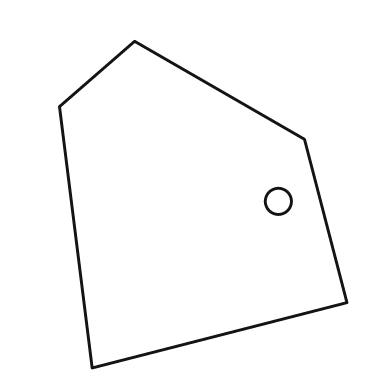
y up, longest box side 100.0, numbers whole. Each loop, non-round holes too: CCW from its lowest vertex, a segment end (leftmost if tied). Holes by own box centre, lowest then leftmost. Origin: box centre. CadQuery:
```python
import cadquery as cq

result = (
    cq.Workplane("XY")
    .moveTo(-34.0, -50.0)
    .lineTo(44.0, -30.0)
    .lineTo(31.0, 20.0)
    .lineTo(-21.0, 50.0)
    .lineTo(-44.0, 30.0)
    .close()
    .moveTo(23.0, 1.0)
    .circle(4.0)
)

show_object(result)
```